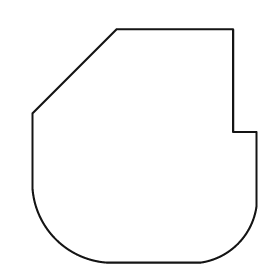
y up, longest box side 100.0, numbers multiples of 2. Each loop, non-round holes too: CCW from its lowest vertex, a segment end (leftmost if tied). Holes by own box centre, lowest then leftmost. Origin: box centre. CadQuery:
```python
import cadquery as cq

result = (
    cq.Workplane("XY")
    .moveTo(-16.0, -50.0)
    .lineTo(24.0, -50.0)
    .threePointArc((40.0, -42.0), (48.0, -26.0))
    .lineTo(48.0, 6.0)
    .lineTo(38.0, 6.0)
    .lineTo(38.0, 50.0)
    .lineTo(-12.0, 50.0)
    .lineTo(-48.0, 14.0)
    .lineTo(-48.0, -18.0)
    .threePointArc((-38.0, -40.0), (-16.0, -50.0))
    .close()
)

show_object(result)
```